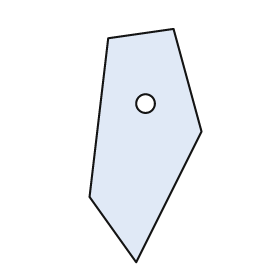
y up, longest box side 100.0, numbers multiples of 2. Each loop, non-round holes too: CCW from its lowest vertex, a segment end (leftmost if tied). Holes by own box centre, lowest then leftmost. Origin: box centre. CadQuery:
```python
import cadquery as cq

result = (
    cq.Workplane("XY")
    .moveTo(-4.0, -50.0)
    .lineTo(24.0, 6.0)
    .lineTo(12.0, 50.0)
    .lineTo(-16.0, 46.0)
    .lineTo(-24.0, -22.0)
    .close()
    .moveTo(0.0, 18.0)
    .circle(4.0)
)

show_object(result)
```